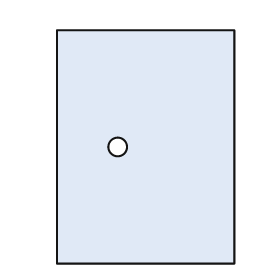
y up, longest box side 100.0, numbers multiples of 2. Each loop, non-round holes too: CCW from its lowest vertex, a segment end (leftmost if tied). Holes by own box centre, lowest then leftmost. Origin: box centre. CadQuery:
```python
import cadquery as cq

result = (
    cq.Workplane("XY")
    .moveTo(-38.0, -50.0)
    .lineTo(38.0, -50.0)
    .lineTo(38.0, 50.0)
    .lineTo(-38.0, 50.0)
    .close()
    .moveTo(-12.0, 0.0)
    .circle(4.0)
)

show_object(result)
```